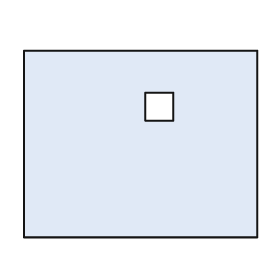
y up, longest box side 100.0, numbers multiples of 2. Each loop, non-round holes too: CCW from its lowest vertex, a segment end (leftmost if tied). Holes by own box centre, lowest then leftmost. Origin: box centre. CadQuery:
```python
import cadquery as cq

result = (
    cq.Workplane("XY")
    .moveTo(-50.0, -40.0)
    .lineTo(50.0, -40.0)
    .lineTo(50.0, 40.0)
    .lineTo(-50.0, 40.0)
    .close()
    .moveTo(2.0, 10.0)
    .lineTo(14.0, 10.0)
    .lineTo(14.0, 22.0)
    .lineTo(2.0, 22.0)
    .close()
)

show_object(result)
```